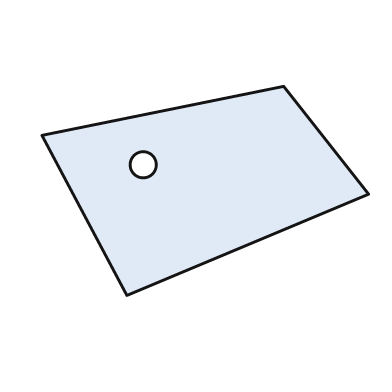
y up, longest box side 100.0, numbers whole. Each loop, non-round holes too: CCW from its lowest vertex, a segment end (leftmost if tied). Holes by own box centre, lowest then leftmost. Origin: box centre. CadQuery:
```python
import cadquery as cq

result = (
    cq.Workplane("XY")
    .moveTo(-24.0, -32.0)
    .lineTo(50.0, -1.0)
    .lineTo(24.0, 32.0)
    .lineTo(-50.0, 17.0)
    .close()
    .moveTo(-19.0, 8.0)
    .circle(4.0)
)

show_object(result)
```